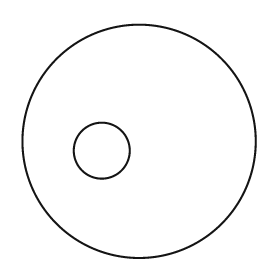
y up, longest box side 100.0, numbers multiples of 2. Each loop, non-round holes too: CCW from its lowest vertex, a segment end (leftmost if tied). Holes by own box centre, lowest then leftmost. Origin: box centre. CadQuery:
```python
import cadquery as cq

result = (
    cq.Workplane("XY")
    .moveTo(0.0, 0.0)
    .circle(50.0)
    .moveTo(-16.0, -4.0)
    .circle(12.0)
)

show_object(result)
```